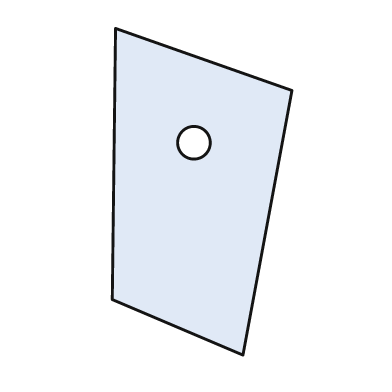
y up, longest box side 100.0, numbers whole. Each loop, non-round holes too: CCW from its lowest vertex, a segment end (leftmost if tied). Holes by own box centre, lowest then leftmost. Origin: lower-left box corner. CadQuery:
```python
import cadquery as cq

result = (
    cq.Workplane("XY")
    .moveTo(40.0, 0.0)
    .lineTo(55.0, 81.0)
    .lineTo(1.0, 100.0)
    .lineTo(0.0, 17.0)
    .close()
    .moveTo(25.0, 65.0)
    .circle(5.0)
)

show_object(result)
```